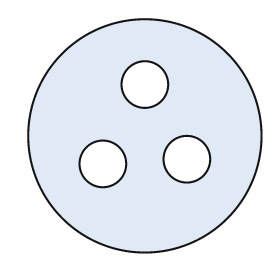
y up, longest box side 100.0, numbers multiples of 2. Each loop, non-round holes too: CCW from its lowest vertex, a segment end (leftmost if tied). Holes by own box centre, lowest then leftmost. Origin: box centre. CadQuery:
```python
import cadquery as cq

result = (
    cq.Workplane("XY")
    .moveTo(0.0, 0.0)
    .circle(50.0)
    .moveTo(-18.0, -12.0)
    .circle(10.0)
    .moveTo(18.0, -10.0)
    .circle(10.0)
    .moveTo(0.0, 22.0)
    .circle(10.0)
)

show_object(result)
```